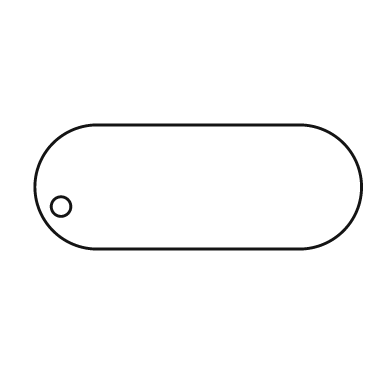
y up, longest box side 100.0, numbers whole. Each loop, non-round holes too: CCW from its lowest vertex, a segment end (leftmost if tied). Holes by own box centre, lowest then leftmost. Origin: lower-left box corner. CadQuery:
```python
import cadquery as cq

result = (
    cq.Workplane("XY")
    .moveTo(19.0, 0.0)
    .lineTo(81.0, 0.0)
    .threePointArc((100.0, 19.0), (81.0, 38.0))
    .lineTo(19.0, 38.0)
    .threePointArc((0.0, 19.0), (19.0, 0.0))
    .close()
    .moveTo(8.0, 13.0)
    .circle(3.0)
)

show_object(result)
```